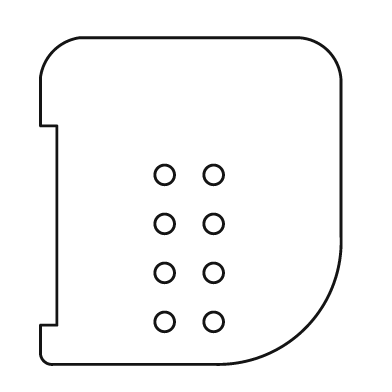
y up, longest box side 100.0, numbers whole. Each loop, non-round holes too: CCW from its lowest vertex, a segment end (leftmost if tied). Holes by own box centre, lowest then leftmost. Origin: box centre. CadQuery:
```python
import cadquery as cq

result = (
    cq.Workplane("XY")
    .moveTo(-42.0, -50.0)
    .lineTo(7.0, -50.0)
    .threePointArc((35.0, -39.0), (46.0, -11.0))
    .lineTo(46.0, 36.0)
    .threePointArc((42.0, 46.0), (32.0, 50.0))
    .lineTo(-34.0, 50.0)
    .threePointArc((-42.0, 46.0), (-46.0, 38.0))
    .lineTo(-46.0, 23.0)
    .lineTo(-41.0, 23.0)
    .lineTo(-41.0, -38.0)
    .lineTo(-46.0, -38.0)
    .lineTo(-46.0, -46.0)
    .threePointArc((-45.0, -49.0), (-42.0, -50.0))
    .close()
    .moveTo(-8.0, -37.0)
    .circle(3.0)
    .moveTo(7.0, -37.0)
    .circle(3.0)
    .moveTo(-8.0, -22.0)
    .circle(3.0)
    .moveTo(7.0, -22.0)
    .circle(3.0)
    .moveTo(-8.0, -7.0)
    .circle(3.0)
    .moveTo(7.0, -7.0)
    .circle(3.0)
    .moveTo(-8.0, 8.0)
    .circle(3.0)
    .moveTo(7.0, 8.0)
    .circle(3.0)
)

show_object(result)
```